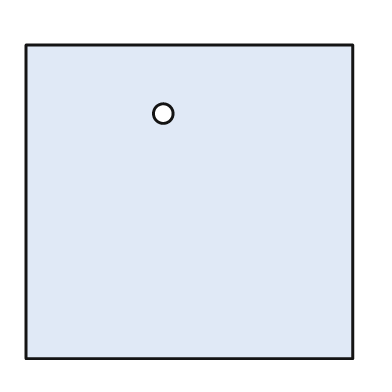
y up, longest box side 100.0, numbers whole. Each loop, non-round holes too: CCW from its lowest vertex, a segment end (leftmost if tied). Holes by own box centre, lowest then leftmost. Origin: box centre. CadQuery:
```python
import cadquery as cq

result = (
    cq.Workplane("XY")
    .moveTo(-50.0, -48.0)
    .lineTo(50.0, -48.0)
    .lineTo(50.0, 48.0)
    .lineTo(-50.0, 48.0)
    .close()
    .moveTo(-8.0, 27.0)
    .circle(3.0)
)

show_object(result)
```